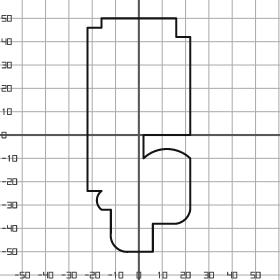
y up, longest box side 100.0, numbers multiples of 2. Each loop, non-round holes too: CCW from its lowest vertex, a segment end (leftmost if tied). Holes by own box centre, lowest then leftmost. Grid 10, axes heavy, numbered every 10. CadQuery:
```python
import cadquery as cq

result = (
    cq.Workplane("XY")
    .moveTo(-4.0, -50.0)
    .lineTo(6.0, -50.0)
    .lineTo(6.0, -38.0)
    .lineTo(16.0, -38.0)
    .threePointArc((20.0, -36.0), (22.0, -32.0))
    .lineTo(22.0, -10.0)
    .threePointArc((12.0, -6.0), (2.0, -10.0))
    .lineTo(2.0, 0.0)
    .lineTo(22.0, 0.0)
    .lineTo(22.0, 42.0)
    .lineTo(16.0, 42.0)
    .lineTo(16.0, 50.0)
    .lineTo(-16.0, 50.0)
    .lineTo(-16.0, 46.0)
    .lineTo(-22.0, 46.0)
    .lineTo(-22.0, -24.0)
    .lineTo(-16.0, -24.0)
    .threePointArc((-18.0, -28.0), (-16.0, -32.0))
    .lineTo(-12.0, -32.0)
    .lineTo(-12.0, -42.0)
    .threePointArc((-10.0, -48.0), (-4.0, -50.0))
    .close()
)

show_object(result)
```